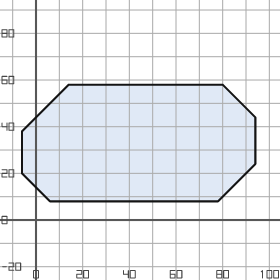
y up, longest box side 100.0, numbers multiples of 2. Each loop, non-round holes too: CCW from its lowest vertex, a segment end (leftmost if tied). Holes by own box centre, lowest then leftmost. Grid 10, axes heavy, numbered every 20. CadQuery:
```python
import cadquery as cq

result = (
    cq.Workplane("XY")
    .moveTo(6.0, 8.0)
    .lineTo(78.0, 8.0)
    .lineTo(94.0, 24.0)
    .lineTo(94.0, 44.0)
    .lineTo(80.0, 58.0)
    .lineTo(14.0, 58.0)
    .lineTo(-6.0, 38.0)
    .lineTo(-6.0, 20.0)
    .close()
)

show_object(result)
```